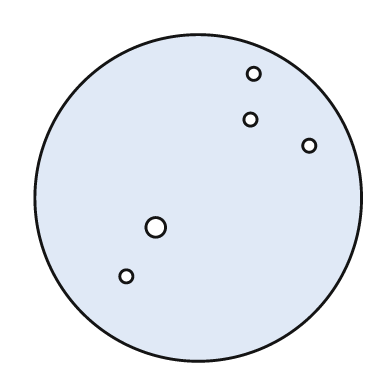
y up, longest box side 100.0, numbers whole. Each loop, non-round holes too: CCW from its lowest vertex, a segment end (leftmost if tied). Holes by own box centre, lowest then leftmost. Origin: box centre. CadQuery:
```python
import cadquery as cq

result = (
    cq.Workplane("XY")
    .moveTo(0.0, 0.0)
    .circle(50.0)
    .moveTo(-22.0, -24.0)
    .circle(2.0)
    .moveTo(-13.0, -9.0)
    .circle(3.0)
    .moveTo(34.0, 16.0)
    .circle(2.0)
    .moveTo(16.0, 24.0)
    .circle(2.0)
    .moveTo(17.0, 38.0)
    .circle(2.0)
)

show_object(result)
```